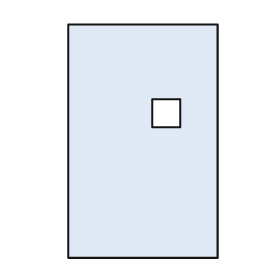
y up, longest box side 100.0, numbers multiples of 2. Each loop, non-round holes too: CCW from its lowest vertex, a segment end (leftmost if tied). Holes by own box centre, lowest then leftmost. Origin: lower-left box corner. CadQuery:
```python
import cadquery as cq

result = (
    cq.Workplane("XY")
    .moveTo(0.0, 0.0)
    .lineTo(64.0, 0.0)
    .lineTo(64.0, 100.0)
    .lineTo(0.0, 100.0)
    .close()
    .moveTo(36.0, 56.0)
    .lineTo(48.0, 56.0)
    .lineTo(48.0, 68.0)
    .lineTo(36.0, 68.0)
    .close()
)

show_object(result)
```